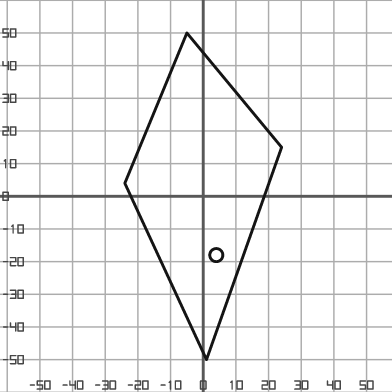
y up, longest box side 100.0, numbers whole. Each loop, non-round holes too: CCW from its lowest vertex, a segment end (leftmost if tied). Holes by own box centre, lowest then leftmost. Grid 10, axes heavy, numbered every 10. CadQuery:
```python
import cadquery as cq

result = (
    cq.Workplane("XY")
    .moveTo(1.0, -50.0)
    .lineTo(24.0, 15.0)
    .lineTo(-5.0, 50.0)
    .lineTo(-24.0, 4.0)
    .close()
    .moveTo(4.0, -18.0)
    .circle(2.0)
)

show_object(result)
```